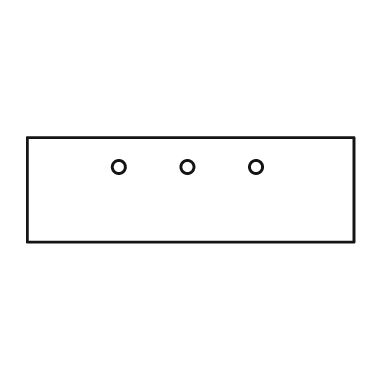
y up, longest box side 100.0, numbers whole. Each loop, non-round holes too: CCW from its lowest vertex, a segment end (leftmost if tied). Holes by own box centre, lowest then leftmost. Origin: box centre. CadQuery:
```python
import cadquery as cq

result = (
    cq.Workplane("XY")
    .moveTo(-50.0, -16.0)
    .lineTo(50.0, -16.0)
    .lineTo(50.0, 16.0)
    .lineTo(-50.0, 16.0)
    .close()
    .moveTo(-22.0, 7.0)
    .circle(2.0)
    .moveTo(-1.0, 7.0)
    .circle(2.0)
    .moveTo(20.0, 7.0)
    .circle(2.0)
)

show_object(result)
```